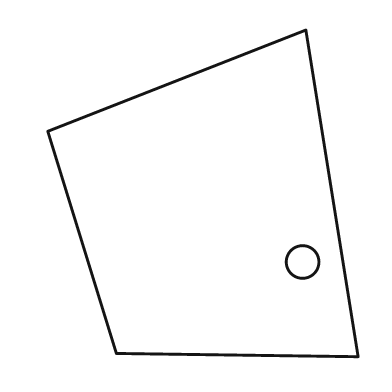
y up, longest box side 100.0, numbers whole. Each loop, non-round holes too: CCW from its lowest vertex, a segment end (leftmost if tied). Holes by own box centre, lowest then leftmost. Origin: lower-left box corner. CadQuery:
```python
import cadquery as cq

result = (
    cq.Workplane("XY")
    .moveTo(95.0, 0.0)
    .lineTo(79.0, 100.0)
    .lineTo(0.0, 69.0)
    .lineTo(21.0, 1.0)
    .close()
    .moveTo(78.0, 29.0)
    .circle(5.0)
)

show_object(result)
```